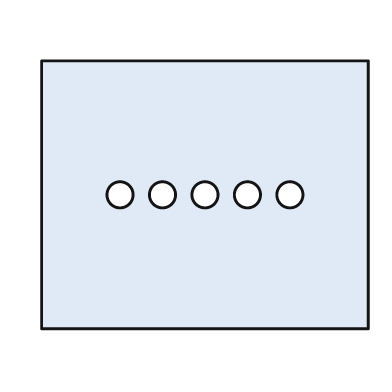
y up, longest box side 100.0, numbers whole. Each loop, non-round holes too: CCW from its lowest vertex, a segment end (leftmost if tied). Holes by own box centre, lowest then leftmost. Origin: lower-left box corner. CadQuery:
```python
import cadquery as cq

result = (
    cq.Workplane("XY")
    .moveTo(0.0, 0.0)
    .lineTo(100.0, 0.0)
    .lineTo(100.0, 82.0)
    .lineTo(0.0, 82.0)
    .close()
    .moveTo(24.0, 41.0)
    .circle(4.0)
    .moveTo(37.0, 41.0)
    .circle(4.0)
    .moveTo(50.0, 41.0)
    .circle(4.0)
    .moveTo(63.0, 41.0)
    .circle(4.0)
    .moveTo(76.0, 41.0)
    .circle(4.0)
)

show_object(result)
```